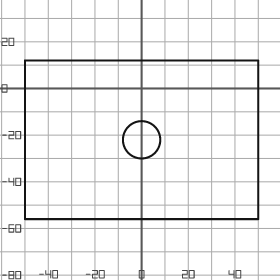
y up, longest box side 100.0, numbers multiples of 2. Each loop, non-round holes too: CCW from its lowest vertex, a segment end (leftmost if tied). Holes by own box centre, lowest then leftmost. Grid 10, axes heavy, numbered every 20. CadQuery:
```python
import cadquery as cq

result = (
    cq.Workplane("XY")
    .moveTo(-50.0, -56.0)
    .lineTo(50.0, -56.0)
    .lineTo(50.0, 12.0)
    .lineTo(-50.0, 12.0)
    .close()
    .moveTo(0.0, -22.0)
    .circle(8.0)
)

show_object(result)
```